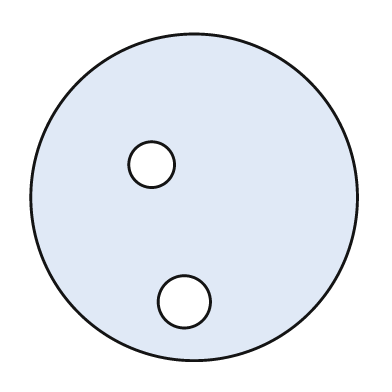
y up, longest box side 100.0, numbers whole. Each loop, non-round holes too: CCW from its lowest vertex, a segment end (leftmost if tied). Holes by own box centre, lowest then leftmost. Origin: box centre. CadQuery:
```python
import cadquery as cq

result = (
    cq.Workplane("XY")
    .moveTo(0.0, 0.0)
    .circle(50.0)
    .moveTo(-3.0, -32.0)
    .circle(8.0)
    .moveTo(-13.0, 10.0)
    .circle(7.0)
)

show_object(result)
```